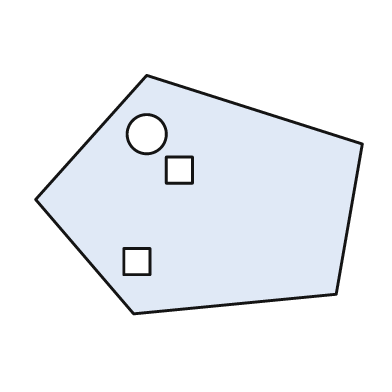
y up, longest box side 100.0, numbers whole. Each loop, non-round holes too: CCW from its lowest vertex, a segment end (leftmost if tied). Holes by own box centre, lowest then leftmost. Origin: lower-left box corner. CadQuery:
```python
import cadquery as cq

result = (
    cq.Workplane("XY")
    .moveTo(30.0, 0.0)
    .lineTo(92.0, 6.0)
    .lineTo(100.0, 52.0)
    .lineTo(34.0, 73.0)
    .lineTo(0.0, 35.0)
    .close()
    .moveTo(27.0, 12.0)
    .lineTo(35.0, 12.0)
    .lineTo(35.0, 20.0)
    .lineTo(27.0, 20.0)
    .close()
    .moveTo(40.0, 40.0)
    .lineTo(48.0, 40.0)
    .lineTo(48.0, 48.0)
    .lineTo(40.0, 48.0)
    .close()
    .moveTo(34.0, 55.0)
    .circle(6.0)
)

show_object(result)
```